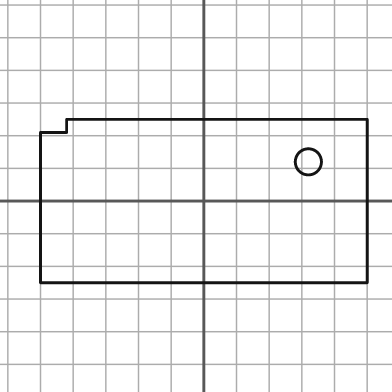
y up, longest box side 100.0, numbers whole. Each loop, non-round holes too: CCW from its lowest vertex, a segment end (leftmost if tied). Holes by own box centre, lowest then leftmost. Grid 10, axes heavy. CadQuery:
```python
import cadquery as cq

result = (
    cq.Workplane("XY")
    .moveTo(-50.0, -25.0)
    .lineTo(50.0, -25.0)
    .lineTo(50.0, 25.0)
    .lineTo(-42.0, 25.0)
    .lineTo(-42.0, 21.0)
    .lineTo(-50.0, 21.0)
    .close()
    .moveTo(32.0, 12.0)
    .circle(4.0)
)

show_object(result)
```